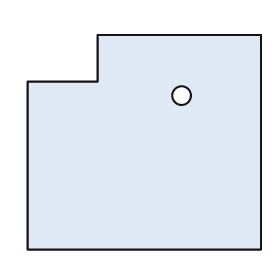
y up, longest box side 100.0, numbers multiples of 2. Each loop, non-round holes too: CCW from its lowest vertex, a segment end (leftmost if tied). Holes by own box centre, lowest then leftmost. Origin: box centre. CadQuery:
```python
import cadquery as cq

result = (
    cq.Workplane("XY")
    .moveTo(-50.0, -46.0)
    .lineTo(50.0, -46.0)
    .lineTo(50.0, 46.0)
    .lineTo(-20.0, 46.0)
    .lineTo(-20.0, 26.0)
    .lineTo(-50.0, 26.0)
    .close()
    .moveTo(16.0, 20.0)
    .circle(4.0)
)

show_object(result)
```